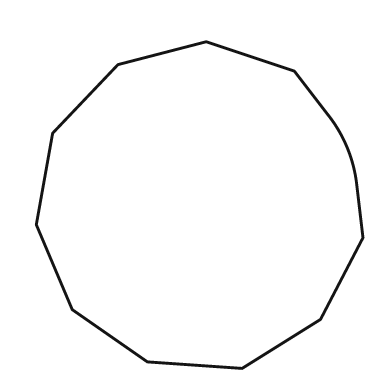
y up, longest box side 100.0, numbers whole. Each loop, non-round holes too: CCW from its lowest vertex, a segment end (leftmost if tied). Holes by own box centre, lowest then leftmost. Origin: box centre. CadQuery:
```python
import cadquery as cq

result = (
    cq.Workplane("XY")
    .moveTo(13.0, -50.0)
    .lineTo(37.0, -35.0)
    .lineTo(50.0, -10.0)
    .lineTo(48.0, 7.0)
    .threePointArc((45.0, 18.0), (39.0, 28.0))
    .lineTo(29.0, 41.0)
    .lineTo(2.0, 50.0)
    .lineTo(-25.0, 43.0)
    .lineTo(-45.0, 22.0)
    .lineTo(-50.0, -6.0)
    .lineTo(-39.0, -32.0)
    .lineTo(-16.0, -48.0)
    .close()
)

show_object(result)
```